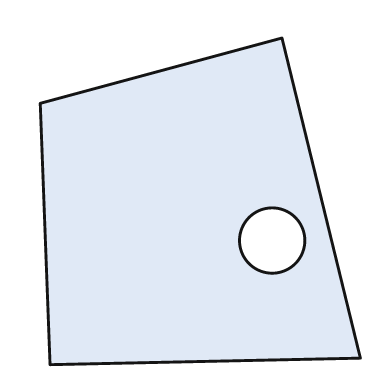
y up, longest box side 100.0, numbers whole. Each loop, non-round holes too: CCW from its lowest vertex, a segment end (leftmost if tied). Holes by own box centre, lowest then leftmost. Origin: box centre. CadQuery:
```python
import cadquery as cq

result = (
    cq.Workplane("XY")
    .moveTo(-46.0, -50.0)
    .lineTo(49.0, -48.0)
    .lineTo(25.0, 50.0)
    .lineTo(-49.0, 30.0)
    .close()
    .moveTo(22.0, -12.0)
    .circle(10.0)
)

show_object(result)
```